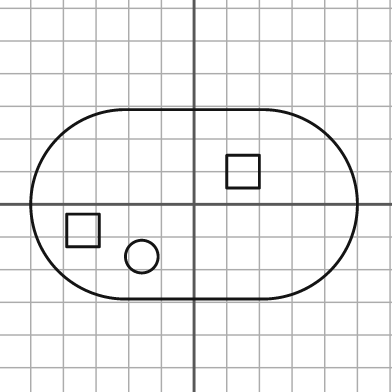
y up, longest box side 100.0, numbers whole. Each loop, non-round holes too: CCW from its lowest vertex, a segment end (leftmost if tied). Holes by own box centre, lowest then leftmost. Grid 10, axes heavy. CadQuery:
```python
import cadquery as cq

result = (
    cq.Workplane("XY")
    .moveTo(-21.0, -29.0)
    .lineTo(21.0, -29.0)
    .threePointArc((50.0, 0.0), (21.0, 29.0))
    .lineTo(-21.0, 29.0)
    .threePointArc((-50.0, 0.0), (-21.0, -29.0))
    .close()
    .moveTo(-16.0, -16.0)
    .circle(5.0)
    .moveTo(-39.0, -13.0)
    .lineTo(-29.0, -13.0)
    .lineTo(-29.0, -3.0)
    .lineTo(-39.0, -3.0)
    .close()
    .moveTo(10.0, 5.0)
    .lineTo(20.0, 5.0)
    .lineTo(20.0, 15.0)
    .lineTo(10.0, 15.0)
    .close()
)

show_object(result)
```